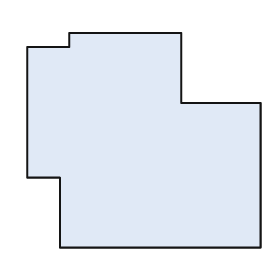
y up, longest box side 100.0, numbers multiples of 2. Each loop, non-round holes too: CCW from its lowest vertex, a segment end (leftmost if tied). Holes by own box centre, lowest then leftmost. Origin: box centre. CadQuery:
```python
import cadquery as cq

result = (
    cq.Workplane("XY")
    .moveTo(-36.0, -46.0)
    .lineTo(50.0, -46.0)
    .lineTo(50.0, 16.0)
    .lineTo(16.0, 16.0)
    .lineTo(16.0, 46.0)
    .lineTo(-32.0, 46.0)
    .lineTo(-32.0, 40.0)
    .lineTo(-50.0, 40.0)
    .lineTo(-50.0, -16.0)
    .lineTo(-36.0, -16.0)
    .close()
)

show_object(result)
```